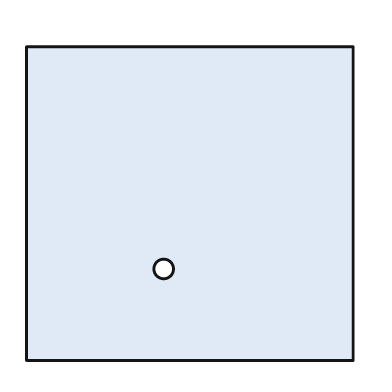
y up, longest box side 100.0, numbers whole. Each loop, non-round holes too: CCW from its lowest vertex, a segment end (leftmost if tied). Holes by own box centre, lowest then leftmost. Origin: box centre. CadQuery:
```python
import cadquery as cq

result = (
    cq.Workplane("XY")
    .moveTo(-50.0, -48.0)
    .lineTo(50.0, -48.0)
    .lineTo(50.0, 48.0)
    .lineTo(-50.0, 48.0)
    .close()
    .moveTo(-8.0, -20.0)
    .circle(3.0)
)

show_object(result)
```